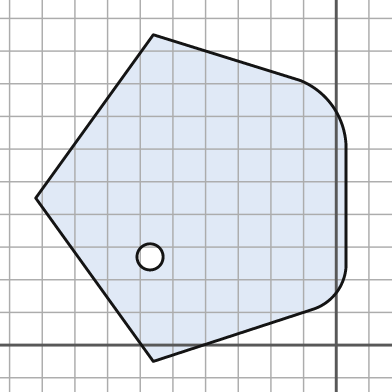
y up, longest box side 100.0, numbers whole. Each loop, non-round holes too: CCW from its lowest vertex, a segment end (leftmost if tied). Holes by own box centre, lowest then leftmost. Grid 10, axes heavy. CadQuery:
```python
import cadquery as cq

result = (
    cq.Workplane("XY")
    .moveTo(-56.0, -5.0)
    .lineTo(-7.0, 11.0)
    .threePointArc((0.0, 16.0), (3.0, 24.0))
    .lineTo(3.0, 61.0)
    .threePointArc((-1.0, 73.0), (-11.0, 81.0))
    .lineTo(-56.0, 95.0)
    .lineTo(-92.0, 45.0)
    .close()
    .moveTo(-57.0, 27.0)
    .circle(4.0)
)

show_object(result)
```